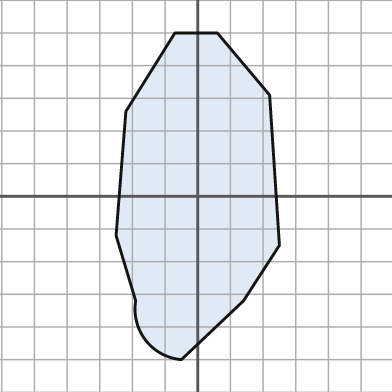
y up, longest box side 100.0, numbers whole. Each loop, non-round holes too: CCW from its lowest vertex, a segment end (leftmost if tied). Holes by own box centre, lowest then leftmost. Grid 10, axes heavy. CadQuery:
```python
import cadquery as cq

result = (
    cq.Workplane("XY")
    .moveTo(-5.0, -50.0)
    .lineTo(14.0, -32.0)
    .lineTo(25.0, -15.0)
    .lineTo(22.0, 31.0)
    .lineTo(6.0, 50.0)
    .lineTo(-7.0, 50.0)
    .lineTo(-22.0, 26.0)
    .lineTo(-25.0, -12.0)
    .lineTo(-19.0, -32.0)
    .threePointArc((-16.0, -44.0), (-5.0, -50.0))
    .close()
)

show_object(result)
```